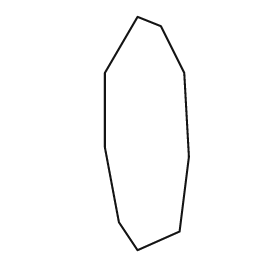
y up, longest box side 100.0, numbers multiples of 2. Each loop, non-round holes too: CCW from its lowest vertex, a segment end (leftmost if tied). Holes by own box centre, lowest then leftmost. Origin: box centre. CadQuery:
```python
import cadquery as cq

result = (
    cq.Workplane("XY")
    .moveTo(-4.0, -50.0)
    .lineTo(14.0, -42.0)
    .lineTo(18.0, -10.0)
    .lineTo(16.0, 26.0)
    .lineTo(6.0, 46.0)
    .lineTo(-4.0, 50.0)
    .lineTo(-18.0, 26.0)
    .lineTo(-18.0, -6.0)
    .lineTo(-12.0, -38.0)
    .close()
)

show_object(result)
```